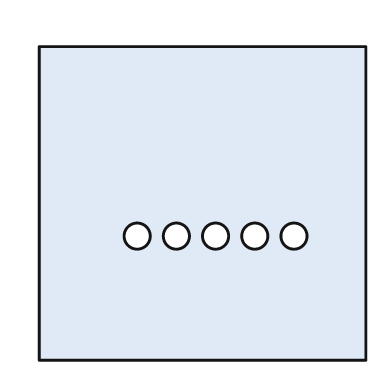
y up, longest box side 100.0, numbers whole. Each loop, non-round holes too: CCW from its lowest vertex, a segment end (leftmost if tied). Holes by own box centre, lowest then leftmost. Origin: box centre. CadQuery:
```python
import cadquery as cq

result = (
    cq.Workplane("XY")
    .moveTo(-50.0, -48.0)
    .lineTo(50.0, -48.0)
    .lineTo(50.0, 48.0)
    .lineTo(-50.0, 48.0)
    .close()
    .moveTo(-20.0, -10.0)
    .circle(4.0)
    .moveTo(-8.0, -10.0)
    .circle(4.0)
    .moveTo(4.0, -10.0)
    .circle(4.0)
    .moveTo(16.0, -10.0)
    .circle(4.0)
    .moveTo(28.0, -10.0)
    .circle(4.0)
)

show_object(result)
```